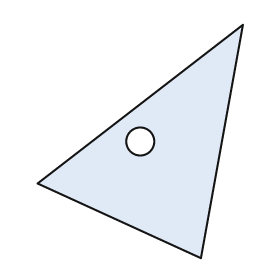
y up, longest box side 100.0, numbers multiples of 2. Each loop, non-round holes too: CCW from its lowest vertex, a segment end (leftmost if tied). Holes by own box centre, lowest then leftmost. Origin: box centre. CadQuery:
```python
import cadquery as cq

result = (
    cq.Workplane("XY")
    .moveTo(26.0, -50.0)
    .lineTo(44.0, 50.0)
    .lineTo(-44.0, -18.0)
    .close()
    .moveTo(0.0, 0.0)
    .circle(6.0)
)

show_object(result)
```